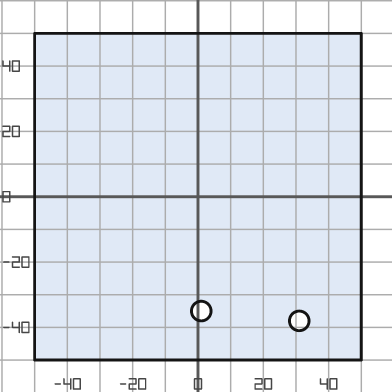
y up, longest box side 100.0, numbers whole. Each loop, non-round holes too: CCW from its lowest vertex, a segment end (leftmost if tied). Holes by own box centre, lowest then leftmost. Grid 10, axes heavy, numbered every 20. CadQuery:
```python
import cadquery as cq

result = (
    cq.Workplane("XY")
    .moveTo(-50.0, -50.0)
    .lineTo(50.0, -50.0)
    .lineTo(50.0, 50.0)
    .lineTo(-50.0, 50.0)
    .close()
    .moveTo(31.0, -38.0)
    .circle(3.0)
    .moveTo(1.0, -35.0)
    .circle(3.0)
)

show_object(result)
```